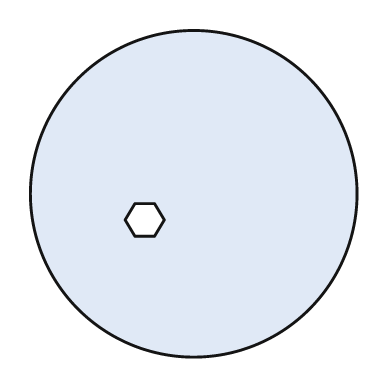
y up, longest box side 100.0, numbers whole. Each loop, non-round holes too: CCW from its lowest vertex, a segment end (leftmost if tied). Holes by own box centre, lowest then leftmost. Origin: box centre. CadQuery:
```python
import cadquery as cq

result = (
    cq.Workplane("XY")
    .moveTo(0.0, 0.0)
    .circle(50.0)
    .moveTo(-18.0, -13.0)
    .lineTo(-12.0, -13.0)
    .lineTo(-9.0, -8.0)
    .lineTo(-12.0, -3.0)
    .lineTo(-18.0, -3.0)
    .lineTo(-21.0, -8.0)
    .close()
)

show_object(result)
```